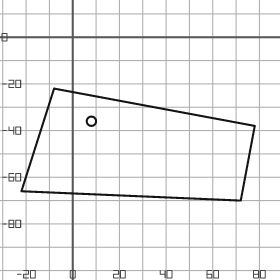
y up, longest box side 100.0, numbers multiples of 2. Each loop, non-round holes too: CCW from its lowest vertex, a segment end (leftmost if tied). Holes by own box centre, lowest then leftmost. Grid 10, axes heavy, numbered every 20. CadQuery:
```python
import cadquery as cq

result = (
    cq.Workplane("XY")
    .moveTo(72.0, -70.0)
    .lineTo(78.0, -38.0)
    .lineTo(-8.0, -22.0)
    .lineTo(-22.0, -66.0)
    .close()
    .moveTo(8.0, -36.0)
    .circle(2.0)
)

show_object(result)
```